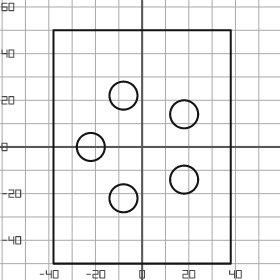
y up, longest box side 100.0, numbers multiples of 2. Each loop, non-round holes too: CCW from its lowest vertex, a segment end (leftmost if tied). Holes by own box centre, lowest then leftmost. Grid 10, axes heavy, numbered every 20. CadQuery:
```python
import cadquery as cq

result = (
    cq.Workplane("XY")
    .moveTo(-38.0, -50.0)
    .lineTo(38.0, -50.0)
    .lineTo(38.0, 50.0)
    .lineTo(-38.0, 50.0)
    .close()
    .moveTo(-8.0, -22.0)
    .circle(6.0)
    .moveTo(18.0, -14.0)
    .circle(6.0)
    .moveTo(-22.0, 0.0)
    .circle(6.0)
    .moveTo(18.0, 14.0)
    .circle(6.0)
    .moveTo(-8.0, 22.0)
    .circle(6.0)
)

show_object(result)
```